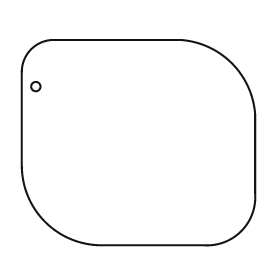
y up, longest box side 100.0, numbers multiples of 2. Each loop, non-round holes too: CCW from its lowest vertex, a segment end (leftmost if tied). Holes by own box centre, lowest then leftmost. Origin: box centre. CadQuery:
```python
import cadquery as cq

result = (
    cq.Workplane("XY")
    .moveTo(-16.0, -44.0)
    .lineTo(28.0, -44.0)
    .threePointArc((44.0, -38.0), (50.0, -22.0))
    .lineTo(50.0, 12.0)
    .threePointArc((40.0, 34.0), (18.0, 44.0))
    .lineTo(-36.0, 44.0)
    .threePointArc((-46.0, 40.0), (-50.0, 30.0))
    .lineTo(-50.0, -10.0)
    .threePointArc((-40.0, -34.0), (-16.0, -44.0))
    .close()
    .moveTo(-44.0, 24.0)
    .circle(2.0)
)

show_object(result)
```